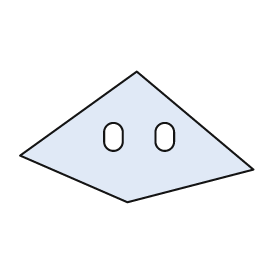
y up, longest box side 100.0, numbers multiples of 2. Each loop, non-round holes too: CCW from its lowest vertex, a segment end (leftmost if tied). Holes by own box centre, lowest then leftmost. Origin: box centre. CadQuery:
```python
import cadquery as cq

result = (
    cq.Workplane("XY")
    .moveTo(-4.0, -28.0)
    .lineTo(50.0, -14.0)
    .lineTo(0.0, 28.0)
    .lineTo(-50.0, -8.0)
    .close()
    .moveTo(-14.0, -2.0)
    .threePointArc((-10.0, -6.0), (-6.0, -2.0))
    .lineTo(-6.0, 2.0)
    .threePointArc((-10.0, 6.0), (-14.0, 2.0))
    .close()
    .moveTo(8.0, -2.0)
    .threePointArc((12.0, -6.0), (16.0, -2.0))
    .lineTo(16.0, 2.0)
    .threePointArc((12.0, 6.0), (8.0, 2.0))
    .close()
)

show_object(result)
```